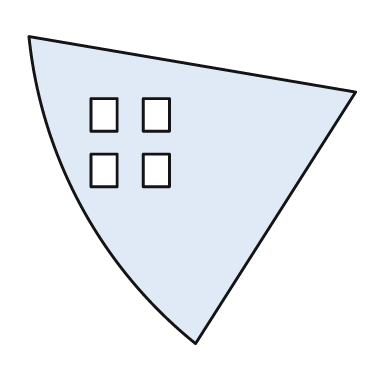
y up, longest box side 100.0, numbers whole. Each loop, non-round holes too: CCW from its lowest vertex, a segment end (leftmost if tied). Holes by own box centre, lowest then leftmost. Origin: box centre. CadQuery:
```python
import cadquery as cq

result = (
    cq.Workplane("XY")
    .moveTo(1.0, -47.0)
    .lineTo(50.0, 30.0)
    .lineTo(-50.0, 47.0)
    .threePointArc((-34.0, -5.0), (1.0, -47.0))
    .close()
    .moveTo(-31.0, 1.0)
    .lineTo(-23.0, 1.0)
    .lineTo(-23.0, 11.0)
    .lineTo(-31.0, 11.0)
    .close()
    .moveTo(-15.0, 1.0)
    .lineTo(-7.0, 1.0)
    .lineTo(-7.0, 11.0)
    .lineTo(-15.0, 11.0)
    .close()
    .moveTo(-31.0, 18.0)
    .lineTo(-23.0, 18.0)
    .lineTo(-23.0, 28.0)
    .lineTo(-31.0, 28.0)
    .close()
    .moveTo(-15.0, 18.0)
    .lineTo(-7.0, 18.0)
    .lineTo(-7.0, 28.0)
    .lineTo(-15.0, 28.0)
    .close()
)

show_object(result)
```